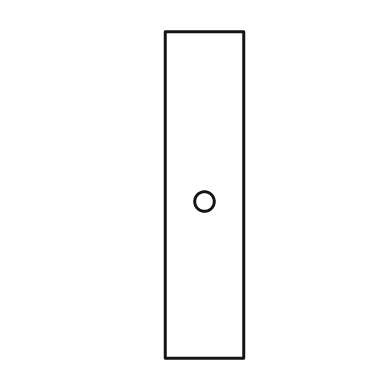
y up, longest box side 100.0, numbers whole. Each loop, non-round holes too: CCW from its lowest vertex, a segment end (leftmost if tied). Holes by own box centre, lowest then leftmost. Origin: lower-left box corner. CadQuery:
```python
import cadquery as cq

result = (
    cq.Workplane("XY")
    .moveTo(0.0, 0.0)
    .lineTo(24.0, 0.0)
    .lineTo(24.0, 100.0)
    .lineTo(0.0, 100.0)
    .close()
    .moveTo(12.0, 48.0)
    .circle(3.0)
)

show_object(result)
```